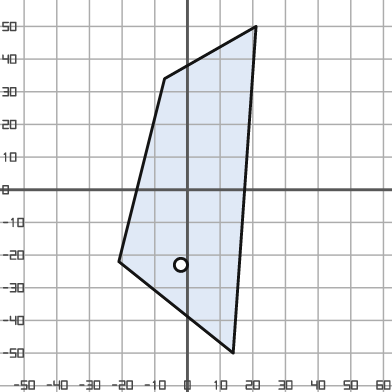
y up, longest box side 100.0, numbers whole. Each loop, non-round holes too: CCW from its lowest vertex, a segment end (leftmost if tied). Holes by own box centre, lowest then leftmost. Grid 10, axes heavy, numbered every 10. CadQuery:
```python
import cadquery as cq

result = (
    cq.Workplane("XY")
    .moveTo(14.0, -50.0)
    .lineTo(21.0, 50.0)
    .lineTo(-7.0, 34.0)
    .lineTo(-21.0, -22.0)
    .close()
    .moveTo(-2.0, -23.0)
    .circle(2.0)
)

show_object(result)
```